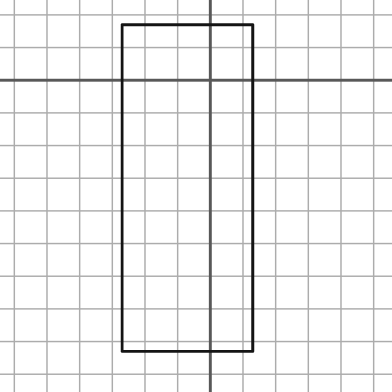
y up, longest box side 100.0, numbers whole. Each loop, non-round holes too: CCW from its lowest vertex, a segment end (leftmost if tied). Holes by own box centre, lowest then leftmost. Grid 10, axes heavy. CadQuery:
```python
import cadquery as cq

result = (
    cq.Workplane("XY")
    .moveTo(-27.0, -83.0)
    .lineTo(13.0, -83.0)
    .lineTo(13.0, 17.0)
    .lineTo(-27.0, 17.0)
    .close()
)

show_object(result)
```